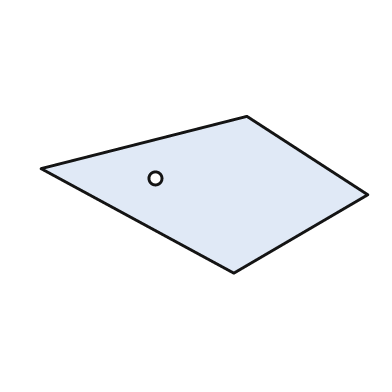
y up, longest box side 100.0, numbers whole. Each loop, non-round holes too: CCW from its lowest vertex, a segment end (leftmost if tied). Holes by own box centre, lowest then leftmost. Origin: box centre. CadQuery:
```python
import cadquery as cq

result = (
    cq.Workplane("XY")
    .moveTo(9.0, -24.0)
    .lineTo(50.0, 0.0)
    .lineTo(13.0, 24.0)
    .lineTo(-50.0, 8.0)
    .close()
    .moveTo(-15.0, 5.0)
    .circle(2.0)
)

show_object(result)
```